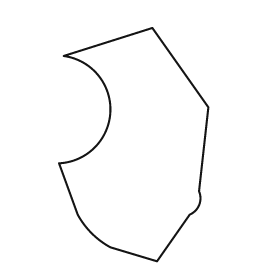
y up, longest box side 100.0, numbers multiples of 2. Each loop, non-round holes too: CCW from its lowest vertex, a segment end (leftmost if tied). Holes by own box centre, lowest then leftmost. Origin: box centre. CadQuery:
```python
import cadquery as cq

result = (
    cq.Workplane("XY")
    .moveTo(10.0, -50.0)
    .lineTo(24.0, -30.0)
    .threePointArc((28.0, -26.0), (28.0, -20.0))
    .lineTo(32.0, 16.0)
    .lineTo(8.0, 50.0)
    .lineTo(-30.0, 38.0)
    .threePointArc((-10.0, 14.0), (-32.0, -8.0))
    .lineTo(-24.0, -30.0)
    .threePointArc((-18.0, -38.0), (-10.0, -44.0))
    .close()
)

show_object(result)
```